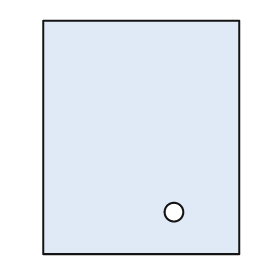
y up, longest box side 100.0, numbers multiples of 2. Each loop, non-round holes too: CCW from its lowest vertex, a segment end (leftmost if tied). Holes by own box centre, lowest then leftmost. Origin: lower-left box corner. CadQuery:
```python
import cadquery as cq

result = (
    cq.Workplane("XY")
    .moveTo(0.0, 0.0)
    .lineTo(84.0, 0.0)
    .lineTo(84.0, 100.0)
    .lineTo(0.0, 100.0)
    .close()
    .moveTo(56.0, 18.0)
    .circle(4.0)
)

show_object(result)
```